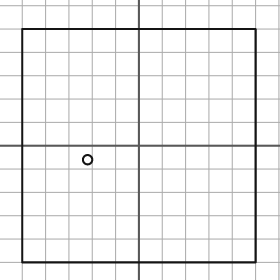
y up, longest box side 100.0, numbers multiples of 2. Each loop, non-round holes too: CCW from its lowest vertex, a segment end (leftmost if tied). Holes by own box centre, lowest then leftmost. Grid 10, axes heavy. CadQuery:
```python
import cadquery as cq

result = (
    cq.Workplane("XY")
    .moveTo(-50.0, -50.0)
    .lineTo(50.0, -50.0)
    .lineTo(50.0, 50.0)
    .lineTo(-50.0, 50.0)
    .close()
    .moveTo(-22.0, -6.0)
    .circle(2.0)
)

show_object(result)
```